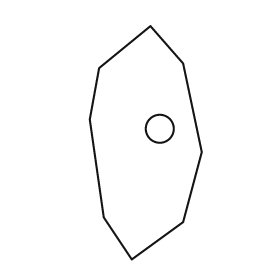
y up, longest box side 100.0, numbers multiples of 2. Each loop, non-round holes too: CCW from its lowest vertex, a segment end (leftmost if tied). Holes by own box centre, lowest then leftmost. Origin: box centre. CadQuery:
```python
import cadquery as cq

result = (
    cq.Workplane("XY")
    .moveTo(-6.0, -50.0)
    .lineTo(16.0, -34.0)
    .lineTo(24.0, -4.0)
    .lineTo(16.0, 34.0)
    .lineTo(2.0, 50.0)
    .lineTo(-20.0, 32.0)
    .lineTo(-24.0, 10.0)
    .lineTo(-18.0, -32.0)
    .close()
    .moveTo(6.0, 6.0)
    .circle(6.0)
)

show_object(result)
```